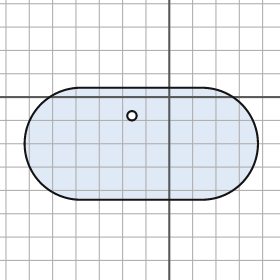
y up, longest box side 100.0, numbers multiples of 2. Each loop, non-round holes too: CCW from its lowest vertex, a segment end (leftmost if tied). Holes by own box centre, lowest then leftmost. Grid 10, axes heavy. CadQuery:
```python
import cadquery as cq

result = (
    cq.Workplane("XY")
    .moveTo(-38.0, -44.0)
    .lineTo(14.0, -44.0)
    .threePointArc((38.0, -20.0), (14.0, 4.0))
    .lineTo(-38.0, 4.0)
    .threePointArc((-62.0, -20.0), (-38.0, -44.0))
    .close()
    .moveTo(-16.0, -8.0)
    .circle(2.0)
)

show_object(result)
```